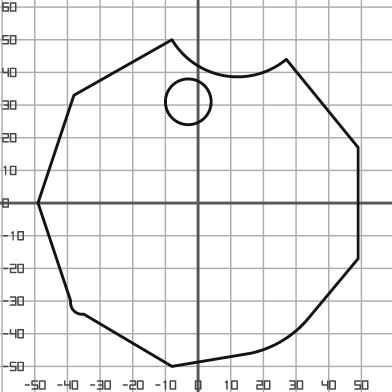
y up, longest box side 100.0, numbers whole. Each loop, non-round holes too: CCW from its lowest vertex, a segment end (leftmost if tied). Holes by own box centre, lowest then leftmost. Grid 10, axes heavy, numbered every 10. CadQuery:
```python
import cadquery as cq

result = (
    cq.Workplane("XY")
    .moveTo(-8.0, -50.0)
    .lineTo(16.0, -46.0)
    .threePointArc((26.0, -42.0), (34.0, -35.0))
    .lineTo(49.0, -17.0)
    .lineTo(49.0, 17.0)
    .lineTo(27.0, 44.0)
    .threePointArc((8.0, 39.0), (-8.0, 50.0))
    .lineTo(-38.0, 33.0)
    .lineTo(-49.0, 0.0)
    .lineTo(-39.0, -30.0)
    .threePointArc((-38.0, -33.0), (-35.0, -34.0))
    .close()
    .moveTo(-3.0, 31.0)
    .circle(7.0)
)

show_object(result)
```